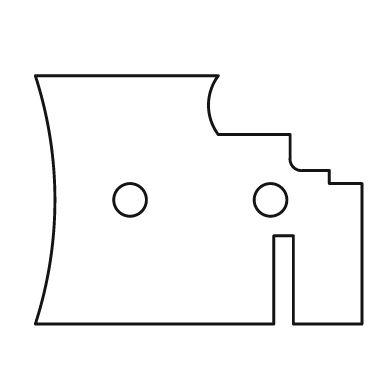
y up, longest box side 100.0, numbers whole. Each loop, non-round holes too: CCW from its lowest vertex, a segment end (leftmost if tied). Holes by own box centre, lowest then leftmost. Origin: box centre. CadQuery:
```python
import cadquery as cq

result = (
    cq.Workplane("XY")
    .moveTo(-50.0, -38.0)
    .lineTo(23.0, -38.0)
    .lineTo(23.0, -11.0)
    .lineTo(29.0, -11.0)
    .lineTo(29.0, -38.0)
    .lineTo(50.0, -38.0)
    .lineTo(50.0, 5.0)
    .lineTo(40.0, 5.0)
    .lineTo(40.0, 9.0)
    .lineTo(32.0, 9.0)
    .threePointArc((29.0, 10.0), (28.0, 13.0))
    .lineTo(28.0, 20.0)
    .lineTo(6.0, 20.0)
    .threePointArc((3.0, 29.0), (6.0, 38.0))
    .lineTo(-50.0, 38.0)
    .threePointArc((-44.0, 0.0), (-50.0, -38.0))
    .close()
    .moveTo(-21.0, 0.0)
    .circle(5.0)
    .moveTo(22.0, 0.0)
    .circle(5.0)
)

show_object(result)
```